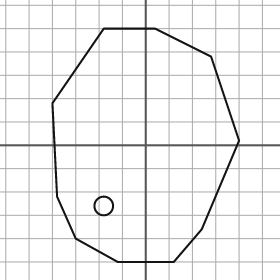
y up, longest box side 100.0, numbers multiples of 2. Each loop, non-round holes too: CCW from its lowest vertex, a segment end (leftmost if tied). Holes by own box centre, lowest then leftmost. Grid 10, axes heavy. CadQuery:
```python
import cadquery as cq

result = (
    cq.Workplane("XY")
    .moveTo(-12.0, -50.0)
    .lineTo(12.0, -50.0)
    .lineTo(24.0, -36.0)
    .lineTo(40.0, 2.0)
    .lineTo(28.0, 38.0)
    .lineTo(4.0, 50.0)
    .lineTo(-18.0, 50.0)
    .lineTo(-40.0, 18.0)
    .lineTo(-38.0, -22.0)
    .lineTo(-30.0, -40.0)
    .close()
    .moveTo(-18.0, -26.0)
    .circle(4.0)
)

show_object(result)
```